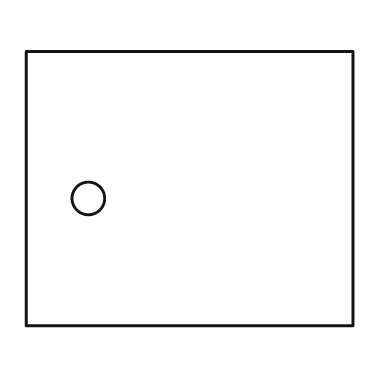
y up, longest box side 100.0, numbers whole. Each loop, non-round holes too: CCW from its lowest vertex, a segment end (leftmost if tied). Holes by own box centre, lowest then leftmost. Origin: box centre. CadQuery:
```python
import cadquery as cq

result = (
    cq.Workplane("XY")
    .moveTo(-50.0, -42.0)
    .lineTo(50.0, -42.0)
    .lineTo(50.0, 42.0)
    .lineTo(-50.0, 42.0)
    .close()
    .moveTo(-31.0, -3.0)
    .circle(5.0)
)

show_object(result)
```